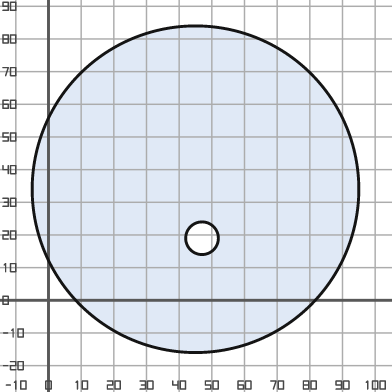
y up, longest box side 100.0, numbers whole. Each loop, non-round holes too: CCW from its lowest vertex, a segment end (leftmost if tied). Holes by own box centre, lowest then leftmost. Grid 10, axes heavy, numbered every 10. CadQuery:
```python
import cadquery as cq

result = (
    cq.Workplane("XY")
    .moveTo(45.0, 34.0)
    .circle(50.0)
    .moveTo(47.0, 19.0)
    .circle(5.0)
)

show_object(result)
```